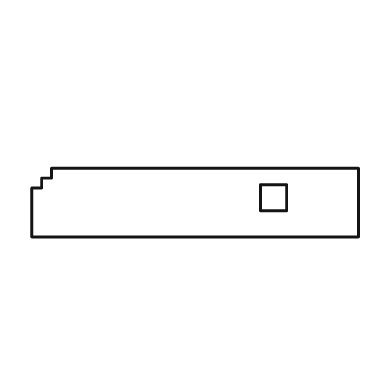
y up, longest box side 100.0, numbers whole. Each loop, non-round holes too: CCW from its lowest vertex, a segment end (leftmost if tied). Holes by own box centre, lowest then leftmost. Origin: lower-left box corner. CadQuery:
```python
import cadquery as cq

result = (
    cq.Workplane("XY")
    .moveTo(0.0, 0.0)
    .lineTo(100.0, 0.0)
    .lineTo(100.0, 21.0)
    .lineTo(6.0, 21.0)
    .lineTo(6.0, 18.0)
    .lineTo(3.0, 18.0)
    .lineTo(3.0, 15.0)
    .lineTo(0.0, 15.0)
    .close()
    .moveTo(70.0, 8.0)
    .lineTo(78.0, 8.0)
    .lineTo(78.0, 16.0)
    .lineTo(70.0, 16.0)
    .close()
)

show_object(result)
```